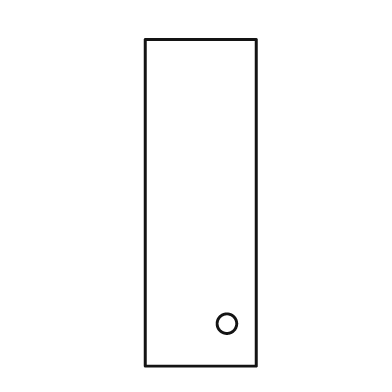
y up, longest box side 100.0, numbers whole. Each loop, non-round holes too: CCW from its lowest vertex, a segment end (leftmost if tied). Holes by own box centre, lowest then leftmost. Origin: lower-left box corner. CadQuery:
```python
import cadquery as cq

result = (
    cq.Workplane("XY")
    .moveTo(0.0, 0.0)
    .lineTo(34.0, 0.0)
    .lineTo(34.0, 100.0)
    .lineTo(0.0, 100.0)
    .close()
    .moveTo(25.0, 13.0)
    .circle(3.0)
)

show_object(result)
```